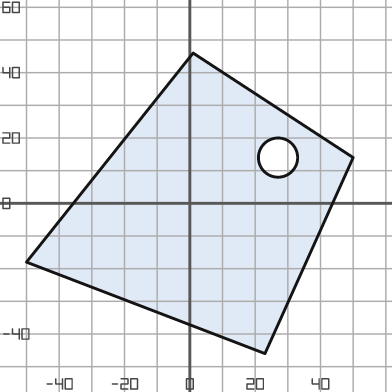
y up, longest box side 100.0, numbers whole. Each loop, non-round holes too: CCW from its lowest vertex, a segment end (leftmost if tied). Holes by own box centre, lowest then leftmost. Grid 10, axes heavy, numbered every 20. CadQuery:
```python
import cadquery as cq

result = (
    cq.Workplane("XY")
    .moveTo(23.0, -46.0)
    .lineTo(50.0, 14.0)
    .lineTo(1.0, 46.0)
    .lineTo(-50.0, -18.0)
    .close()
    .moveTo(27.0, 14.0)
    .circle(6.0)
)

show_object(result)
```